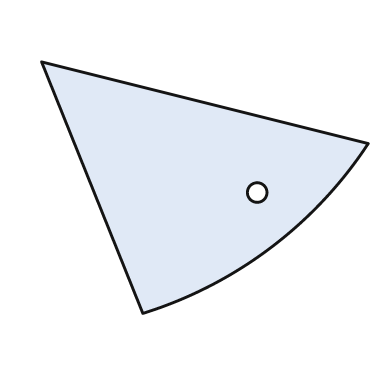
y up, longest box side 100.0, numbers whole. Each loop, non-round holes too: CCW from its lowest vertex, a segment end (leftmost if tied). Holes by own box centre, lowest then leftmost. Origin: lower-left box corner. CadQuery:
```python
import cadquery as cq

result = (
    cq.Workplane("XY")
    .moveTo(31.0, 0.0)
    .threePointArc((70.0, 20.0), (100.0, 52.0))
    .lineTo(0.0, 77.0)
    .close()
    .moveTo(66.0, 37.0)
    .circle(3.0)
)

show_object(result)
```